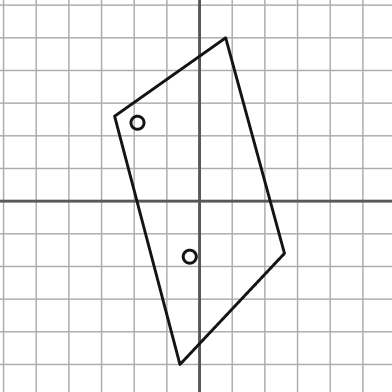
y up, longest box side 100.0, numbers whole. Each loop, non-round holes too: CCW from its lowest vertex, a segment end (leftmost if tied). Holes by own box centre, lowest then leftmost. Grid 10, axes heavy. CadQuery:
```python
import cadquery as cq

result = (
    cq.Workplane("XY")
    .moveTo(-6.0, -50.0)
    .lineTo(26.0, -16.0)
    .lineTo(8.0, 50.0)
    .lineTo(-26.0, 26.0)
    .close()
    .moveTo(-3.0, -17.0)
    .circle(2.0)
    .moveTo(-19.0, 24.0)
    .circle(2.0)
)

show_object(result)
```